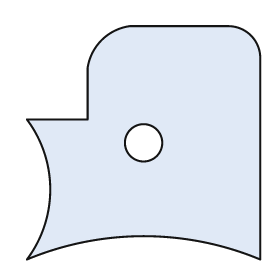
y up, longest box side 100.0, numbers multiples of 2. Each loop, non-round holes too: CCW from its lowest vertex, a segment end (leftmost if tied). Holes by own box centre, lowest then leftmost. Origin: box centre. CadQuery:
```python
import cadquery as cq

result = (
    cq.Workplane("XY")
    .moveTo(-50.0, -50.0)
    .threePointArc((0.0, -40.0), (50.0, -50.0))
    .lineTo(50.0, 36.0)
    .threePointArc((46.0, 46.0), (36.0, 50.0))
    .lineTo(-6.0, 50.0)
    .threePointArc((-18.0, 44.0), (-24.0, 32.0))
    .lineTo(-24.0, 10.0)
    .lineTo(-50.0, 10.0)
    .threePointArc((-40.0, -20.0), (-50.0, -50.0))
    .close()
    .moveTo(0.0, 0.0)
    .circle(8.0)
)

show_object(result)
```